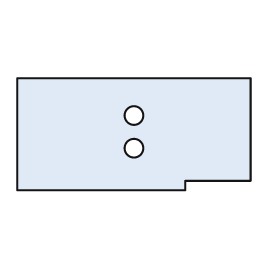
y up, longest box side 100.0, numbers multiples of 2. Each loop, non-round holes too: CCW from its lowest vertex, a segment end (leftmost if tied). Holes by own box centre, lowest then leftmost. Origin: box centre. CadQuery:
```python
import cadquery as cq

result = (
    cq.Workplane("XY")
    .moveTo(-50.0, -24.0)
    .lineTo(22.0, -24.0)
    .lineTo(22.0, -20.0)
    .lineTo(50.0, -20.0)
    .lineTo(50.0, 24.0)
    .lineTo(-50.0, 24.0)
    .close()
    .moveTo(0.0, -6.0)
    .circle(4.0)
    .moveTo(0.0, 8.0)
    .circle(4.0)
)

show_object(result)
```